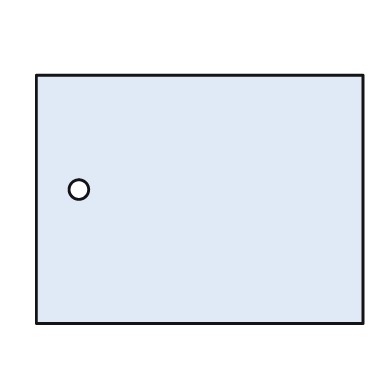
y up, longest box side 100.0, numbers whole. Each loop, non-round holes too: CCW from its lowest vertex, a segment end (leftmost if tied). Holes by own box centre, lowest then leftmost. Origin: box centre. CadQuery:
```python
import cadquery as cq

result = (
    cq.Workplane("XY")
    .moveTo(-50.0, -38.0)
    .lineTo(50.0, -38.0)
    .lineTo(50.0, 38.0)
    .lineTo(-50.0, 38.0)
    .close()
    .moveTo(-37.0, 3.0)
    .circle(3.0)
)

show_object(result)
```